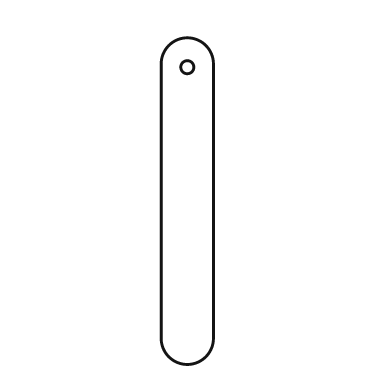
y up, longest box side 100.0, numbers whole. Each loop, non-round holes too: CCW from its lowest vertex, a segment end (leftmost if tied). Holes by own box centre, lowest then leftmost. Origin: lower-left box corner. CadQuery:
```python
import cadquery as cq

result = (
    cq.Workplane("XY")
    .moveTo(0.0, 8.0)
    .threePointArc((8.0, 0.0), (16.0, 8.0))
    .lineTo(16.0, 92.0)
    .threePointArc((8.0, 100.0), (0.0, 92.0))
    .close()
    .moveTo(8.0, 91.0)
    .circle(2.0)
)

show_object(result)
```